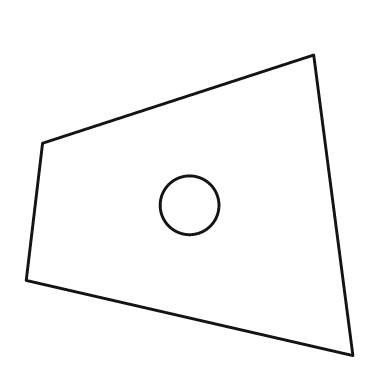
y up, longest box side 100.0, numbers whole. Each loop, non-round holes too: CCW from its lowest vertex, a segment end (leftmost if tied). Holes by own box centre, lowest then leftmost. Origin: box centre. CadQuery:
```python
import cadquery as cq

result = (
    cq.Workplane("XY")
    .moveTo(50.0, -46.0)
    .lineTo(38.0, 46.0)
    .lineTo(-45.0, 19.0)
    .lineTo(-50.0, -23.0)
    .close()
    .moveTo(0.0, 0.0)
    .circle(9.0)
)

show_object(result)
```